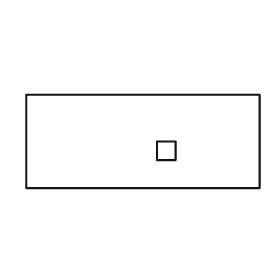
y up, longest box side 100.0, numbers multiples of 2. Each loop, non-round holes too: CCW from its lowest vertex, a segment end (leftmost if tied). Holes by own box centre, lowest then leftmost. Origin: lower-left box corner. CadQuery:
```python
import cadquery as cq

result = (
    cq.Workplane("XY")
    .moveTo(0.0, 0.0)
    .lineTo(100.0, 0.0)
    .lineTo(100.0, 40.0)
    .lineTo(0.0, 40.0)
    .close()
    .moveTo(56.0, 12.0)
    .lineTo(64.0, 12.0)
    .lineTo(64.0, 20.0)
    .lineTo(56.0, 20.0)
    .close()
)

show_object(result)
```